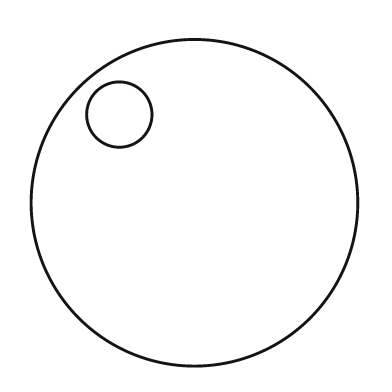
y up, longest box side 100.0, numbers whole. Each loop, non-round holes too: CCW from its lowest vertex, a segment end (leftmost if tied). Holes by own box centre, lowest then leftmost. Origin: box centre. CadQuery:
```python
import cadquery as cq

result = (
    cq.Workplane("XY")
    .moveTo(0.0, 0.0)
    .circle(50.0)
    .moveTo(-23.0, 27.0)
    .circle(10.0)
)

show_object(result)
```